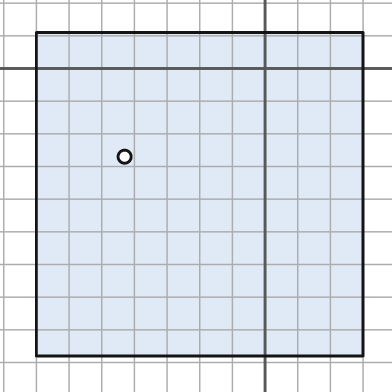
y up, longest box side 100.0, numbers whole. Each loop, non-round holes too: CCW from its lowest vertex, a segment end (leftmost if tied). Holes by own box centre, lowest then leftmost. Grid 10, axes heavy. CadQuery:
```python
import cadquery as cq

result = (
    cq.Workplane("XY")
    .moveTo(-70.0, -88.0)
    .lineTo(30.0, -88.0)
    .lineTo(30.0, 11.0)
    .lineTo(-70.0, 11.0)
    .close()
    .moveTo(-43.0, -27.0)
    .circle(2.0)
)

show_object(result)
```